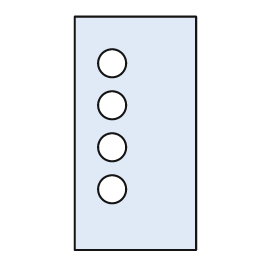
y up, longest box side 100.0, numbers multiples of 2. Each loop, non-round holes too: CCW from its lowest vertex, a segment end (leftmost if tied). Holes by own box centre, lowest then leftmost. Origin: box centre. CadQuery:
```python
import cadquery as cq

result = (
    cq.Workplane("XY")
    .moveTo(-26.0, -50.0)
    .lineTo(26.0, -50.0)
    .lineTo(26.0, 50.0)
    .lineTo(-26.0, 50.0)
    .close()
    .moveTo(-10.0, -24.0)
    .circle(6.0)
    .moveTo(-10.0, -6.0)
    .circle(6.0)
    .moveTo(-10.0, 12.0)
    .circle(6.0)
    .moveTo(-10.0, 30.0)
    .circle(6.0)
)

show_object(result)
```